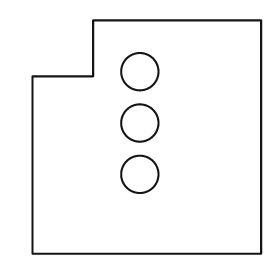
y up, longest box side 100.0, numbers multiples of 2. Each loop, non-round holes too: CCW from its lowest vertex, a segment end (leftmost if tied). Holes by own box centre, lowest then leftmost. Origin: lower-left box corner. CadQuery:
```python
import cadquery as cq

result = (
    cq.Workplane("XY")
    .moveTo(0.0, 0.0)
    .lineTo(98.0, 0.0)
    .lineTo(98.0, 100.0)
    .lineTo(26.0, 100.0)
    .lineTo(26.0, 76.0)
    .lineTo(0.0, 76.0)
    .close()
    .moveTo(46.0, 34.0)
    .circle(8.0)
    .moveTo(46.0, 56.0)
    .circle(8.0)
    .moveTo(46.0, 78.0)
    .circle(8.0)
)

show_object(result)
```